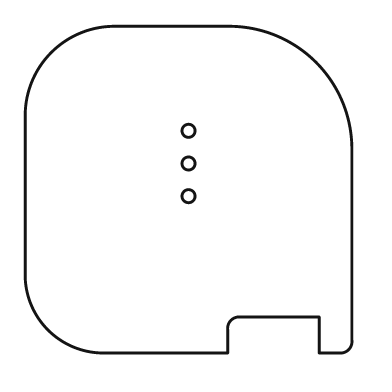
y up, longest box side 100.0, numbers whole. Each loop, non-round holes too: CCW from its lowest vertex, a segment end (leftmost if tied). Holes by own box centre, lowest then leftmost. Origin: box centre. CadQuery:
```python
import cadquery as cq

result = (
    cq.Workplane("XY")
    .moveTo(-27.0, -50.0)
    .lineTo(12.0, -50.0)
    .lineTo(12.0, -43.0)
    .threePointArc((13.0, -40.0), (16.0, -39.0))
    .lineTo(40.0, -39.0)
    .lineTo(40.0, -50.0)
    .lineTo(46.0, -50.0)
    .threePointArc((49.0, -49.0), (50.0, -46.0))
    .lineTo(50.0, 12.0)
    .threePointArc((39.0, 39.0), (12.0, 50.0))
    .lineTo(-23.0, 50.0)
    .threePointArc((-42.0, 42.0), (-50.0, 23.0))
    .lineTo(-50.0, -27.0)
    .threePointArc((-43.0, -43.0), (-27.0, -50.0))
    .close()
    .moveTo(0.0, -2.0)
    .circle(2.0)
    .moveTo(0.0, 8.0)
    .circle(2.0)
    .moveTo(0.0, 18.0)
    .circle(2.0)
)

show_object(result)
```